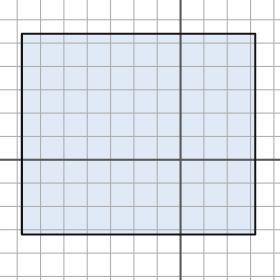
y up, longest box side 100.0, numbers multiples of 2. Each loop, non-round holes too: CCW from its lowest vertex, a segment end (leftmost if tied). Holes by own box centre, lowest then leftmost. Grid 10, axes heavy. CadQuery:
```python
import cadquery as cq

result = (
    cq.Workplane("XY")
    .moveTo(-68.0, -32.0)
    .lineTo(32.0, -32.0)
    .lineTo(32.0, 54.0)
    .lineTo(-68.0, 54.0)
    .close()
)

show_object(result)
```